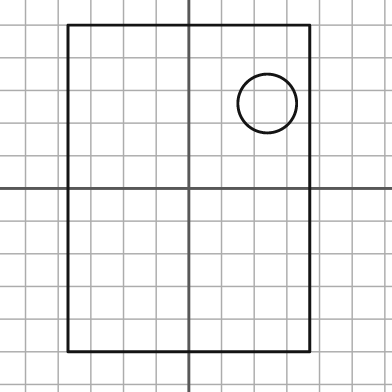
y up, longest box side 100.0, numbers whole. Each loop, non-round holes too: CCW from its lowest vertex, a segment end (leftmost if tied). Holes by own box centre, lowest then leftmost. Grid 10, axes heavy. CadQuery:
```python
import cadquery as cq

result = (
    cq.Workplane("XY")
    .moveTo(-37.0, -50.0)
    .lineTo(37.0, -50.0)
    .lineTo(37.0, 50.0)
    .lineTo(-37.0, 50.0)
    .close()
    .moveTo(24.0, 26.0)
    .circle(9.0)
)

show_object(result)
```